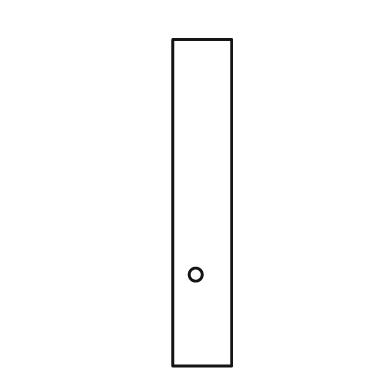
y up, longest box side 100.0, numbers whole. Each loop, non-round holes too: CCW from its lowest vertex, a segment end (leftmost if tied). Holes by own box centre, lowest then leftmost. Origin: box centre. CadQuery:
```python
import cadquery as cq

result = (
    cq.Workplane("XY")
    .moveTo(-9.0, -50.0)
    .lineTo(9.0, -50.0)
    .lineTo(9.0, 50.0)
    .lineTo(-9.0, 50.0)
    .close()
    .moveTo(-2.0, -22.0)
    .circle(2.0)
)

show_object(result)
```